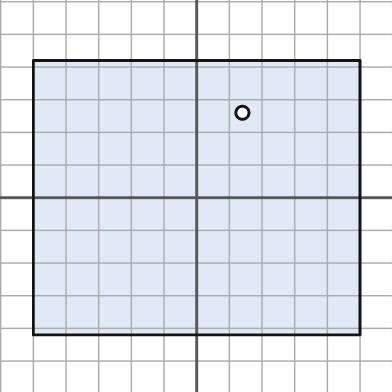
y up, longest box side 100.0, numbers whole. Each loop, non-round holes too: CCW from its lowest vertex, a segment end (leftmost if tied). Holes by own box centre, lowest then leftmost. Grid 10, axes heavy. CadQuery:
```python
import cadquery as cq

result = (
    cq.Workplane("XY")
    .moveTo(-50.0, -42.0)
    .lineTo(50.0, -42.0)
    .lineTo(50.0, 42.0)
    .lineTo(-50.0, 42.0)
    .close()
    .moveTo(14.0, 26.0)
    .circle(2.0)
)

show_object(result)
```